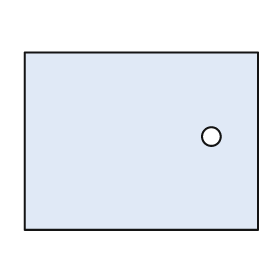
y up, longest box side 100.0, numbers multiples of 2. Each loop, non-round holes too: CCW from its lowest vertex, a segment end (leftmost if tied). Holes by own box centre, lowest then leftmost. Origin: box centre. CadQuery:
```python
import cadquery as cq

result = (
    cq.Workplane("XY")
    .moveTo(-50.0, -38.0)
    .lineTo(50.0, -38.0)
    .lineTo(50.0, 38.0)
    .lineTo(-50.0, 38.0)
    .close()
    .moveTo(30.0, 2.0)
    .circle(4.0)
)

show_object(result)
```